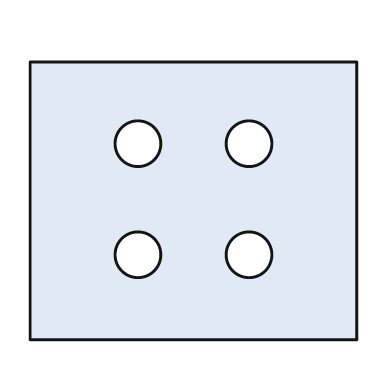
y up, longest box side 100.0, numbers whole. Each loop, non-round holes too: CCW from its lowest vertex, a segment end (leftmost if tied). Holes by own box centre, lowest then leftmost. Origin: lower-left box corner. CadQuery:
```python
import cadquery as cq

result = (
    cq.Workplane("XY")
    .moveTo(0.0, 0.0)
    .lineTo(100.0, 0.0)
    .lineTo(100.0, 85.0)
    .lineTo(0.0, 85.0)
    .close()
    .moveTo(33.0, 26.0)
    .circle(7.0)
    .moveTo(67.0, 26.0)
    .circle(7.0)
    .moveTo(33.0, 60.0)
    .circle(7.0)
    .moveTo(67.0, 60.0)
    .circle(7.0)
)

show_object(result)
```